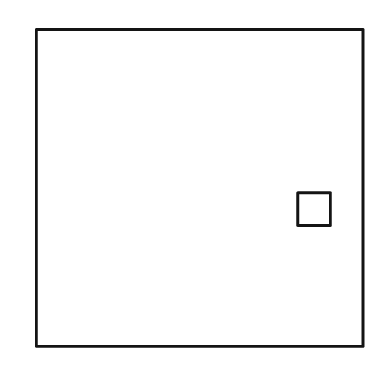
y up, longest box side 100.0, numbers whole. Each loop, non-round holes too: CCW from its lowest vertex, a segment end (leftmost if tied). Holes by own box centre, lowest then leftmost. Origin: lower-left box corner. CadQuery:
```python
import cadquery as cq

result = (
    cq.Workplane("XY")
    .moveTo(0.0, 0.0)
    .lineTo(100.0, 0.0)
    .lineTo(100.0, 97.0)
    .lineTo(0.0, 97.0)
    .close()
    .moveTo(80.0, 37.0)
    .lineTo(90.0, 37.0)
    .lineTo(90.0, 47.0)
    .lineTo(80.0, 47.0)
    .close()
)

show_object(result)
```